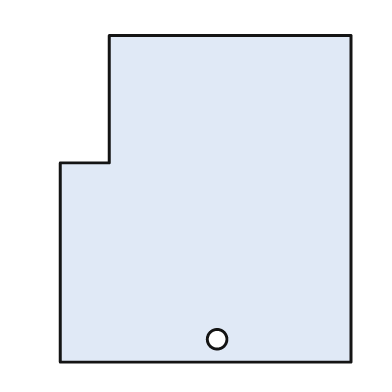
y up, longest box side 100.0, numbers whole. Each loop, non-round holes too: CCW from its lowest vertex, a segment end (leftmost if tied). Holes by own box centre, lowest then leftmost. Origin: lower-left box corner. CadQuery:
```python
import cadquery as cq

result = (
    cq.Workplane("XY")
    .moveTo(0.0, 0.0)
    .lineTo(89.0, 0.0)
    .lineTo(89.0, 100.0)
    .lineTo(15.0, 100.0)
    .lineTo(15.0, 61.0)
    .lineTo(0.0, 61.0)
    .close()
    .moveTo(48.0, 7.0)
    .circle(3.0)
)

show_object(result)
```